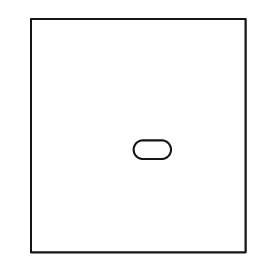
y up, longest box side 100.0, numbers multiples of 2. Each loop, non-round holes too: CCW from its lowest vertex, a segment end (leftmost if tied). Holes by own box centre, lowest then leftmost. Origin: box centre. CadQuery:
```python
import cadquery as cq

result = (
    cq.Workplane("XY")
    .moveTo(-46.0, -50.0)
    .lineTo(46.0, -50.0)
    .lineTo(46.0, 50.0)
    .lineTo(-46.0, 50.0)
    .close()
    .moveTo(2.0, -10.0)
    .lineTo(10.0, -10.0)
    .threePointArc((14.0, -6.0), (10.0, -2.0))
    .lineTo(2.0, -2.0)
    .threePointArc((-2.0, -6.0), (2.0, -10.0))
    .close()
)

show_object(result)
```